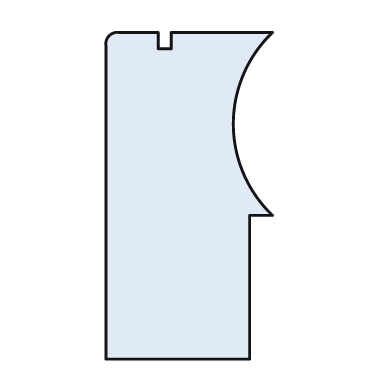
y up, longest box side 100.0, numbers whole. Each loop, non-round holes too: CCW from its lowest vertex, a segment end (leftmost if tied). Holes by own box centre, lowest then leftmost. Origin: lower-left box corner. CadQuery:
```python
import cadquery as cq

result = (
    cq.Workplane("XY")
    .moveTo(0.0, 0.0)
    .lineTo(44.0, 0.0)
    .lineTo(44.0, 44.0)
    .lineTo(51.0, 44.0)
    .threePointArc((39.0, 72.0), (51.0, 100.0))
    .lineTo(20.0, 100.0)
    .lineTo(20.0, 95.0)
    .lineTo(16.0, 95.0)
    .lineTo(16.0, 100.0)
    .lineTo(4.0, 100.0)
    .threePointArc((1.0, 99.0), (0.0, 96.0))
    .close()
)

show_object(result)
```